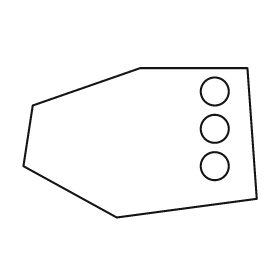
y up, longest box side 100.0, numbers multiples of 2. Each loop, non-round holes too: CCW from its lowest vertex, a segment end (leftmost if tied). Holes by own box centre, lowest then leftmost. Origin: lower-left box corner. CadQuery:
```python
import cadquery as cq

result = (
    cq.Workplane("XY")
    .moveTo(40.0, 0.0)
    .lineTo(100.0, 8.0)
    .lineTo(96.0, 64.0)
    .lineTo(50.0, 64.0)
    .lineTo(4.0, 48.0)
    .lineTo(0.0, 22.0)
    .close()
    .moveTo(82.0, 22.0)
    .circle(6.0)
    .moveTo(82.0, 38.0)
    .circle(6.0)
    .moveTo(82.0, 54.0)
    .circle(6.0)
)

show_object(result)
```